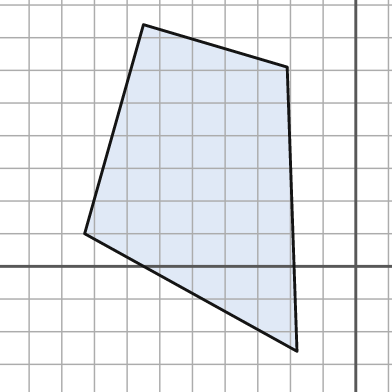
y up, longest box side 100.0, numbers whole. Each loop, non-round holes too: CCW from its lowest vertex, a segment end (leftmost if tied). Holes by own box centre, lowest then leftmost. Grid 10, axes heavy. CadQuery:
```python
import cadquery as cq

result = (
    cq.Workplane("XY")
    .moveTo(-18.0, -26.0)
    .lineTo(-21.0, 61.0)
    .lineTo(-65.0, 74.0)
    .lineTo(-83.0, 10.0)
    .close()
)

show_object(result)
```